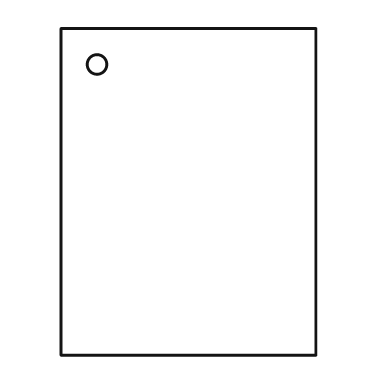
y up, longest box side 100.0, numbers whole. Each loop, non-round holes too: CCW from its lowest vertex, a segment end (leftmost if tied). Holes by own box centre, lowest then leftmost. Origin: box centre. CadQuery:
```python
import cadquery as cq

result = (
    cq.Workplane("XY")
    .moveTo(-39.0, -50.0)
    .lineTo(39.0, -50.0)
    .lineTo(39.0, 50.0)
    .lineTo(-39.0, 50.0)
    .close()
    .moveTo(-28.0, 39.0)
    .circle(3.0)
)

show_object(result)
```